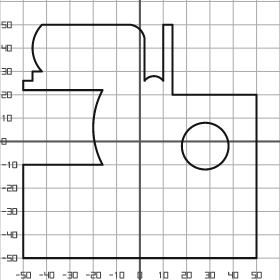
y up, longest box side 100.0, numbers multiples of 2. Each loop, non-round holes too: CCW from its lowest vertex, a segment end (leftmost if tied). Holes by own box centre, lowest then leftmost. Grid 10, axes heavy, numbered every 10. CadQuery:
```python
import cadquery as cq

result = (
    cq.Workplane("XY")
    .moveTo(-50.0, -50.0)
    .lineTo(50.0, -50.0)
    .lineTo(50.0, 20.0)
    .lineTo(14.0, 20.0)
    .lineTo(14.0, 50.0)
    .lineTo(10.0, 50.0)
    .lineTo(10.0, 26.0)
    .threePointArc((6.0, 28.0), (2.0, 26.0))
    .lineTo(2.0, 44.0)
    .threePointArc((0.0, 48.0), (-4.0, 50.0))
    .lineTo(-42.0, 50.0)
    .threePointArc((-46.0, 40.0), (-42.0, 30.0))
    .lineTo(-46.0, 30.0)
    .lineTo(-46.0, 26.0)
    .lineTo(-50.0, 26.0)
    .lineTo(-50.0, 22.0)
    .lineTo(-16.0, 22.0)
    .threePointArc((-20.0, 6.0), (-16.0, -10.0))
    .lineTo(-50.0, -10.0)
    .close()
    .moveTo(28.0, -2.0)
    .circle(10.0)
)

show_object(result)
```